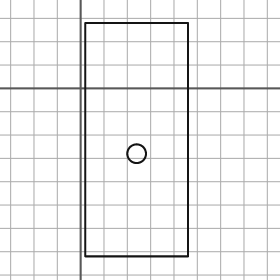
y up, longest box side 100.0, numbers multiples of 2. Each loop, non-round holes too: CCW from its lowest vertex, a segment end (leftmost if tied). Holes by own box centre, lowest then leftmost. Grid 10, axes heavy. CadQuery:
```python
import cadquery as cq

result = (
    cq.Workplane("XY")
    .moveTo(2.0, -72.0)
    .lineTo(46.0, -72.0)
    .lineTo(46.0, 28.0)
    .lineTo(2.0, 28.0)
    .close()
    .moveTo(24.0, -28.0)
    .circle(4.0)
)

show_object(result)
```